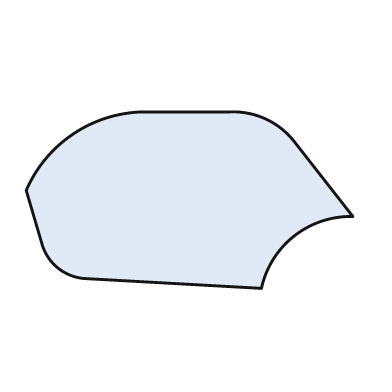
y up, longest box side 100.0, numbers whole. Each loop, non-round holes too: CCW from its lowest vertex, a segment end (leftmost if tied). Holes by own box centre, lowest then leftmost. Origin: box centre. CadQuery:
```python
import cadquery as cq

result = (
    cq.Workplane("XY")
    .moveTo(22.0, -27.0)
    .threePointArc((32.0, -11.0), (50.0, -5.0))
    .lineTo(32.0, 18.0)
    .threePointArc((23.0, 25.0), (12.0, 27.0))
    .lineTo(-15.0, 27.0)
    .threePointArc((-36.0, 20.0), (-50.0, 3.0))
    .lineTo(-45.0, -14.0)
    .threePointArc((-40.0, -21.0), (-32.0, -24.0))
    .close()
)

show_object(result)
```